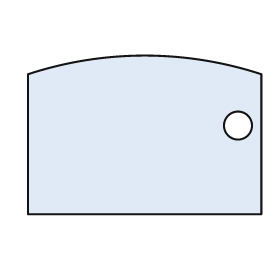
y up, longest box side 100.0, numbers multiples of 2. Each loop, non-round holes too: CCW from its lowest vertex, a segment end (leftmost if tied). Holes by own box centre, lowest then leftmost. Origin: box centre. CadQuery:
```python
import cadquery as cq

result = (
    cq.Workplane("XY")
    .moveTo(-50.0, -34.0)
    .lineTo(50.0, -34.0)
    .lineTo(50.0, 26.0)
    .threePointArc((0.0, 34.0), (-50.0, 26.0))
    .close()
    .moveTo(40.0, 4.0)
    .circle(6.0)
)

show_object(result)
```